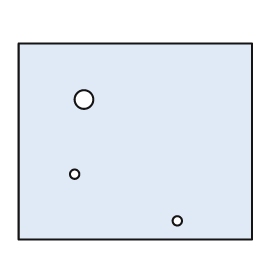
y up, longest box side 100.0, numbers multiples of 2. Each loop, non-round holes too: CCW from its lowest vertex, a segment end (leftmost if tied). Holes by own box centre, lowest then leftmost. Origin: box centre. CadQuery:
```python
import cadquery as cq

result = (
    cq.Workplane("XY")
    .moveTo(-50.0, -42.0)
    .lineTo(50.0, -42.0)
    .lineTo(50.0, 42.0)
    .lineTo(-50.0, 42.0)
    .close()
    .moveTo(18.0, -34.0)
    .circle(2.0)
    .moveTo(-26.0, -14.0)
    .circle(2.0)
    .moveTo(-22.0, 18.0)
    .circle(4.0)
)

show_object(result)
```